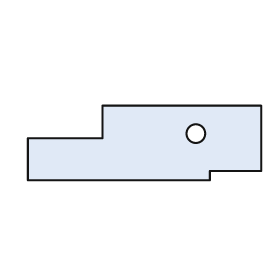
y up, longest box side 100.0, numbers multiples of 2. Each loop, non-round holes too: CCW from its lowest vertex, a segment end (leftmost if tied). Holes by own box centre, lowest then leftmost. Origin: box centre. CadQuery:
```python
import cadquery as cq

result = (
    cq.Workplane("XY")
    .moveTo(-50.0, -16.0)
    .lineTo(28.0, -16.0)
    .lineTo(28.0, -12.0)
    .lineTo(50.0, -12.0)
    .lineTo(50.0, 16.0)
    .lineTo(-18.0, 16.0)
    .lineTo(-18.0, 2.0)
    .lineTo(-50.0, 2.0)
    .close()
    .moveTo(22.0, 4.0)
    .circle(4.0)
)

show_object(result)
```